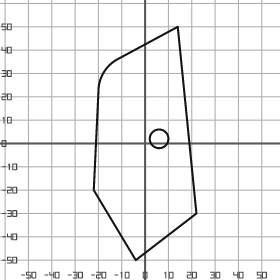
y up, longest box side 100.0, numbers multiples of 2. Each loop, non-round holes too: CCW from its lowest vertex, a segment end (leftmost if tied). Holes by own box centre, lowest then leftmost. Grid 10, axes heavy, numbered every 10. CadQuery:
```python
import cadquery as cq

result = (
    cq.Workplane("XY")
    .moveTo(-4.0, -50.0)
    .lineTo(22.0, -30.0)
    .lineTo(14.0, 50.0)
    .lineTo(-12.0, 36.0)
    .threePointArc((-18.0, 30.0), (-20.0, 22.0))
    .lineTo(-22.0, -20.0)
    .close()
    .moveTo(6.0, 2.0)
    .circle(4.0)
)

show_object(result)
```